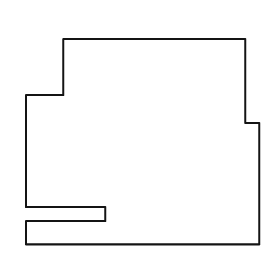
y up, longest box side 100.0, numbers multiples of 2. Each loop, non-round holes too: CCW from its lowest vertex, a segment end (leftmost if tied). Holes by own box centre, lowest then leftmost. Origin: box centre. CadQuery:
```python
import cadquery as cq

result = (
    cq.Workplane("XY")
    .moveTo(-50.0, -44.0)
    .lineTo(50.0, -44.0)
    .lineTo(50.0, 8.0)
    .lineTo(44.0, 8.0)
    .lineTo(44.0, 44.0)
    .lineTo(-34.0, 44.0)
    .lineTo(-34.0, 20.0)
    .lineTo(-50.0, 20.0)
    .lineTo(-50.0, -28.0)
    .lineTo(-16.0, -28.0)
    .lineTo(-16.0, -34.0)
    .lineTo(-50.0, -34.0)
    .close()
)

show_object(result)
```